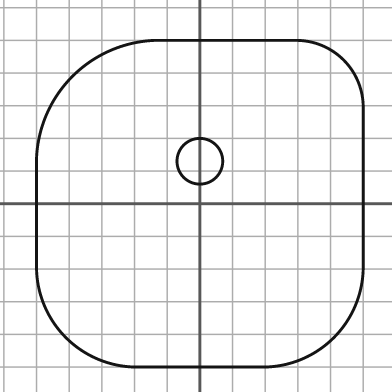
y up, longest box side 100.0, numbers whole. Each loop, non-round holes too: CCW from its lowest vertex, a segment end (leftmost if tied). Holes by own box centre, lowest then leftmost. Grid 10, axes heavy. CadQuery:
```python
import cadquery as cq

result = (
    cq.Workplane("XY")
    .moveTo(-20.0, -50.0)
    .lineTo(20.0, -50.0)
    .threePointArc((41.0, -41.0), (50.0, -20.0))
    .lineTo(50.0, 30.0)
    .threePointArc((44.0, 44.0), (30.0, 50.0))
    .lineTo(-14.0, 50.0)
    .threePointArc((-39.0, 39.0), (-50.0, 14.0))
    .lineTo(-50.0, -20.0)
    .threePointArc((-41.0, -41.0), (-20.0, -50.0))
    .close()
    .moveTo(0.0, 13.0)
    .circle(7.0)
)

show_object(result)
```